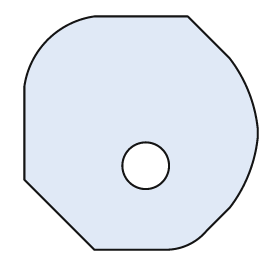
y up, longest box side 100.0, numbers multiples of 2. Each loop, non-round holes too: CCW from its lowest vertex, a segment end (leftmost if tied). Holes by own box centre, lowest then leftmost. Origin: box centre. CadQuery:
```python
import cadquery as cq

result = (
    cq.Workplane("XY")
    .moveTo(-20.0, -50.0)
    .lineTo(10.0, -50.0)
    .threePointArc((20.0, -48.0), (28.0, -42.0))
    .lineTo(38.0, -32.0)
    .threePointArc((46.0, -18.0), (50.0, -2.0))
    .lineTo(50.0, 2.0)
    .threePointArc((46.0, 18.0), (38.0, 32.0))
    .lineTo(20.0, 50.0)
    .lineTo(-20.0, 50.0)
    .threePointArc((-40.0, 40.0), (-50.0, 20.0))
    .lineTo(-50.0, -20.0)
    .close()
    .moveTo(2.0, -14.0)
    .circle(10.0)
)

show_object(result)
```